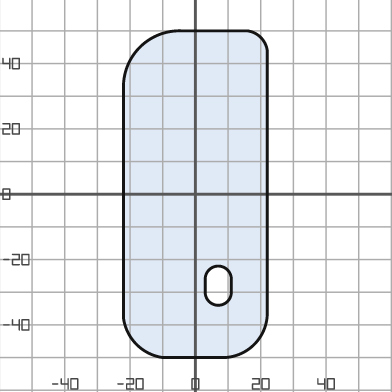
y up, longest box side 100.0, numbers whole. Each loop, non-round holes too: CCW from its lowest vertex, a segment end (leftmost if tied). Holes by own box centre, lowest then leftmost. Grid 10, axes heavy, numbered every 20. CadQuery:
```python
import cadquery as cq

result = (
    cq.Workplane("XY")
    .moveTo(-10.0, -50.0)
    .lineTo(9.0, -50.0)
    .threePointArc((18.0, -46.0), (22.0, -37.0))
    .lineTo(22.0, 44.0)
    .threePointArc((20.0, 48.0), (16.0, 50.0))
    .lineTo(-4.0, 50.0)
    .threePointArc((-17.0, 45.0), (-22.0, 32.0))
    .lineTo(-22.0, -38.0)
    .threePointArc((-18.0, -46.0), (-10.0, -50.0))
    .close()
    .moveTo(3.0, -30.0)
    .threePointArc((7.0, -34.0), (11.0, -30.0))
    .lineTo(11.0, -26.0)
    .threePointArc((7.0, -22.0), (3.0, -26.0))
    .close()
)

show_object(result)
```